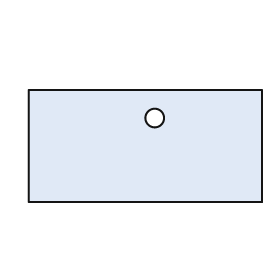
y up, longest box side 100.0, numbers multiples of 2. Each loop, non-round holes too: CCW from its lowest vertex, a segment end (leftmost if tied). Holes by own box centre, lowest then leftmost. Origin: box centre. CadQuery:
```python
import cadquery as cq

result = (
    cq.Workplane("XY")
    .moveTo(-50.0, -24.0)
    .lineTo(50.0, -24.0)
    .lineTo(50.0, 24.0)
    .lineTo(-50.0, 24.0)
    .close()
    .moveTo(4.0, 12.0)
    .circle(4.0)
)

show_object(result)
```